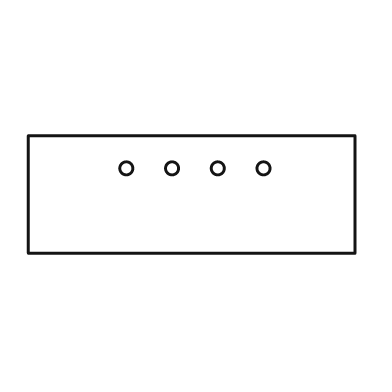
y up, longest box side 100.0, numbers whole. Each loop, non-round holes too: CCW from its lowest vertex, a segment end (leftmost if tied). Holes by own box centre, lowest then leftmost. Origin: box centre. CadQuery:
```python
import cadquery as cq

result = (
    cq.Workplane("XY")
    .moveTo(-50.0, -18.0)
    .lineTo(50.0, -18.0)
    .lineTo(50.0, 18.0)
    .lineTo(-50.0, 18.0)
    .close()
    .moveTo(-20.0, 8.0)
    .circle(2.0)
    .moveTo(-6.0, 8.0)
    .circle(2.0)
    .moveTo(8.0, 8.0)
    .circle(2.0)
    .moveTo(22.0, 8.0)
    .circle(2.0)
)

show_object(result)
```